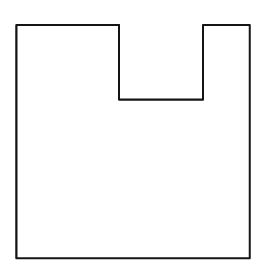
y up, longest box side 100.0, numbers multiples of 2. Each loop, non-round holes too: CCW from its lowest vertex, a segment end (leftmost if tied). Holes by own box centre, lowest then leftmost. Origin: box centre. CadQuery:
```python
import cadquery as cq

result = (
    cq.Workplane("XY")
    .moveTo(-50.0, -50.0)
    .lineTo(50.0, -50.0)
    .lineTo(50.0, 50.0)
    .lineTo(30.0, 50.0)
    .lineTo(30.0, 18.0)
    .lineTo(-6.0, 18.0)
    .lineTo(-6.0, 50.0)
    .lineTo(-50.0, 50.0)
    .close()
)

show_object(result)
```